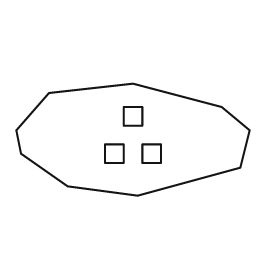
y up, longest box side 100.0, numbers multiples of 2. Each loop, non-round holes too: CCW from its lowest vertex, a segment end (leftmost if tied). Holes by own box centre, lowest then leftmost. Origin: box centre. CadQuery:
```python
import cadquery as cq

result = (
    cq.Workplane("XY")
    .moveTo(2.0, -24.0)
    .lineTo(46.0, -12.0)
    .lineTo(50.0, 4.0)
    .lineTo(38.0, 14.0)
    .lineTo(0.0, 24.0)
    .lineTo(-36.0, 20.0)
    .lineTo(-50.0, 4.0)
    .lineTo(-48.0, -6.0)
    .lineTo(-28.0, -20.0)
    .close()
    .moveTo(-12.0, -10.0)
    .lineTo(-4.0, -10.0)
    .lineTo(-4.0, -2.0)
    .lineTo(-12.0, -2.0)
    .close()
    .moveTo(4.0, -10.0)
    .lineTo(12.0, -10.0)
    .lineTo(12.0, -2.0)
    .lineTo(4.0, -2.0)
    .close()
    .moveTo(-4.0, 6.0)
    .lineTo(4.0, 6.0)
    .lineTo(4.0, 14.0)
    .lineTo(-4.0, 14.0)
    .close()
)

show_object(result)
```